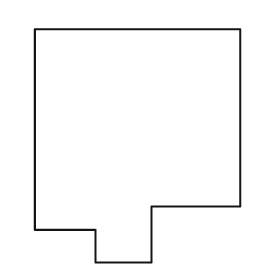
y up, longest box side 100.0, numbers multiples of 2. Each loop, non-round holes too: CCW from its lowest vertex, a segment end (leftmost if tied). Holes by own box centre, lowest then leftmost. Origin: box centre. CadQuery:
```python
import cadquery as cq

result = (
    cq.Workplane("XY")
    .moveTo(-18.0, -50.0)
    .lineTo(6.0, -50.0)
    .lineTo(6.0, -26.0)
    .lineTo(44.0, -26.0)
    .lineTo(44.0, 50.0)
    .lineTo(-44.0, 50.0)
    .lineTo(-44.0, -36.0)
    .lineTo(-18.0, -36.0)
    .close()
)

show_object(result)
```